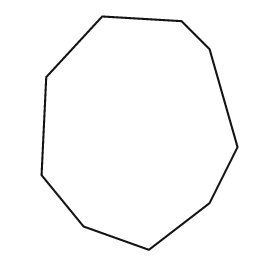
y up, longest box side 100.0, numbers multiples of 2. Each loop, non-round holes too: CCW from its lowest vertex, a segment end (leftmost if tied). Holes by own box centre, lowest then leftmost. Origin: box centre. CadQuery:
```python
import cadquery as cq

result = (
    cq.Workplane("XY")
    .moveTo(4.0, -50.0)
    .lineTo(30.0, -30.0)
    .lineTo(42.0, -6.0)
    .lineTo(30.0, 36.0)
    .lineTo(18.0, 48.0)
    .lineTo(-16.0, 50.0)
    .lineTo(-40.0, 24.0)
    .lineTo(-42.0, -18.0)
    .lineTo(-24.0, -40.0)
    .close()
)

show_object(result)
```